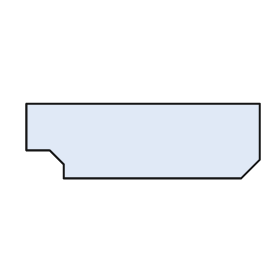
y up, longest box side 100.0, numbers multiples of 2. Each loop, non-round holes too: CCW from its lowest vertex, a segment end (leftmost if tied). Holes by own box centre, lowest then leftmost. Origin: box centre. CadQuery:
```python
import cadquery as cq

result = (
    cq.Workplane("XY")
    .moveTo(-34.0, -16.0)
    .lineTo(42.0, -16.0)
    .lineTo(50.0, -8.0)
    .lineTo(50.0, 16.0)
    .lineTo(-50.0, 16.0)
    .lineTo(-50.0, -4.0)
    .lineTo(-40.0, -4.0)
    .lineTo(-34.0, -10.0)
    .close()
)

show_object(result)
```